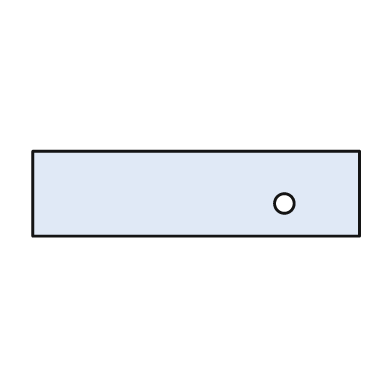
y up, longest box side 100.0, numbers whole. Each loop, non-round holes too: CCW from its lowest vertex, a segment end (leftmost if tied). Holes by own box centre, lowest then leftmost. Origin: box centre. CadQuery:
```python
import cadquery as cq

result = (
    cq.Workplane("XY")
    .moveTo(-50.0, -13.0)
    .lineTo(50.0, -13.0)
    .lineTo(50.0, 13.0)
    .lineTo(-50.0, 13.0)
    .close()
    .moveTo(27.0, -3.0)
    .circle(3.0)
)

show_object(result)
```